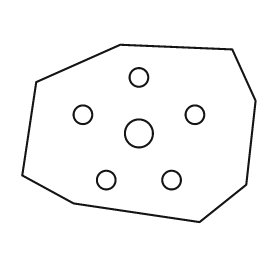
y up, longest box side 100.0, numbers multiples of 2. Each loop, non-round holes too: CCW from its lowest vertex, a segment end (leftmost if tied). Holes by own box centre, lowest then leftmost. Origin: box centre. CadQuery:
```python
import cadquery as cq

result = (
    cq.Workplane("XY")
    .moveTo(26.0, -38.0)
    .lineTo(46.0, -22.0)
    .lineTo(50.0, 14.0)
    .lineTo(40.0, 36.0)
    .lineTo(-8.0, 38.0)
    .lineTo(-44.0, 22.0)
    .lineTo(-50.0, -18.0)
    .lineTo(-28.0, -30.0)
    .close()
    .moveTo(-14.0, -20.0)
    .circle(4.0)
    .moveTo(14.0, -20.0)
    .circle(4.0)
    .moveTo(0.0, 0.0)
    .circle(6.0)
    .moveTo(-24.0, 8.0)
    .circle(4.0)
    .moveTo(24.0, 8.0)
    .circle(4.0)
    .moveTo(0.0, 24.0)
    .circle(4.0)
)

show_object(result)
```